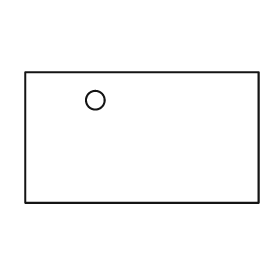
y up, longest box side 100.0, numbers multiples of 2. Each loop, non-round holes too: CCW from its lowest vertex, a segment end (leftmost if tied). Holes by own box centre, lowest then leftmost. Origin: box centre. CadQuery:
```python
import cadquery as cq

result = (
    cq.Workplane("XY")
    .moveTo(-50.0, -28.0)
    .lineTo(50.0, -28.0)
    .lineTo(50.0, 28.0)
    .lineTo(-50.0, 28.0)
    .close()
    .moveTo(-20.0, 16.0)
    .circle(4.0)
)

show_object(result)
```